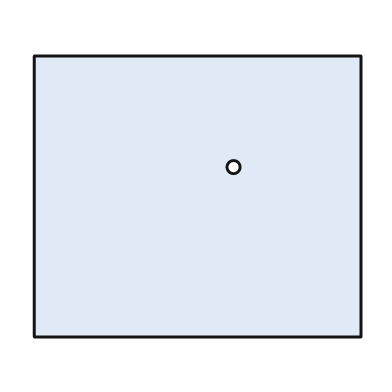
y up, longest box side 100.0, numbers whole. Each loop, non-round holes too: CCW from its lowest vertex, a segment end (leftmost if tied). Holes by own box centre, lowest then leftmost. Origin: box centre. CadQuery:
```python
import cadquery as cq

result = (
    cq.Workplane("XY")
    .moveTo(-50.0, -43.0)
    .lineTo(50.0, -43.0)
    .lineTo(50.0, 43.0)
    .lineTo(-50.0, 43.0)
    .close()
    .moveTo(11.0, 9.0)
    .circle(2.0)
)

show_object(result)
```